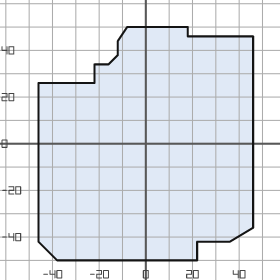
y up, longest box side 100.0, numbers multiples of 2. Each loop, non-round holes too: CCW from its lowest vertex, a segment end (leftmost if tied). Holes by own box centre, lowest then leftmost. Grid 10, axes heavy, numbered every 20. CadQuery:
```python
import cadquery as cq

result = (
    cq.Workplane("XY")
    .moveTo(-38.0, -50.0)
    .lineTo(22.0, -50.0)
    .lineTo(22.0, -42.0)
    .lineTo(36.0, -42.0)
    .lineTo(46.0, -36.0)
    .lineTo(46.0, 46.0)
    .lineTo(18.0, 46.0)
    .lineTo(18.0, 50.0)
    .lineTo(-8.0, 50.0)
    .lineTo(-12.0, 44.0)
    .lineTo(-12.0, 38.0)
    .lineTo(-16.0, 34.0)
    .lineTo(-22.0, 34.0)
    .lineTo(-22.0, 26.0)
    .lineTo(-46.0, 26.0)
    .lineTo(-46.0, -42.0)
    .close()
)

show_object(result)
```